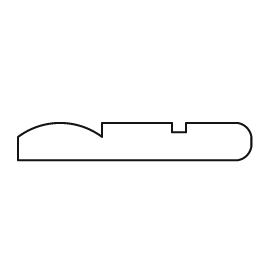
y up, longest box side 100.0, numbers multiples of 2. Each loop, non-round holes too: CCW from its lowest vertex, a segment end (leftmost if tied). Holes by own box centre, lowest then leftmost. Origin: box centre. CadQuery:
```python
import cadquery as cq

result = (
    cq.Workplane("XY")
    .moveTo(-50.0, -8.0)
    .lineTo(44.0, -8.0)
    .threePointArc((48.0, -6.0), (50.0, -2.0))
    .lineTo(50.0, 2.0)
    .threePointArc((48.0, 6.0), (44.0, 8.0))
    .lineTo(22.0, 8.0)
    .lineTo(22.0, 4.0)
    .lineTo(16.0, 4.0)
    .lineTo(16.0, 8.0)
    .lineTo(-14.0, 8.0)
    .lineTo(-14.0, 2.0)
    .threePointArc((-32.0, 8.0), (-50.0, 2.0))
    .close()
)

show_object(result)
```